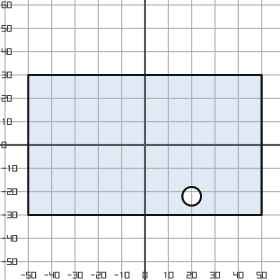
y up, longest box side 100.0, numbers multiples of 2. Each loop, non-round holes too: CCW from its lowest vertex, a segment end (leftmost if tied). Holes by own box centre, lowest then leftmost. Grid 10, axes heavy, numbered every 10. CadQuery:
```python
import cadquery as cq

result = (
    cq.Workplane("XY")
    .moveTo(-50.0, -30.0)
    .lineTo(50.0, -30.0)
    .lineTo(50.0, 30.0)
    .lineTo(-50.0, 30.0)
    .close()
    .moveTo(20.0, -22.0)
    .circle(4.0)
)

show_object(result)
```